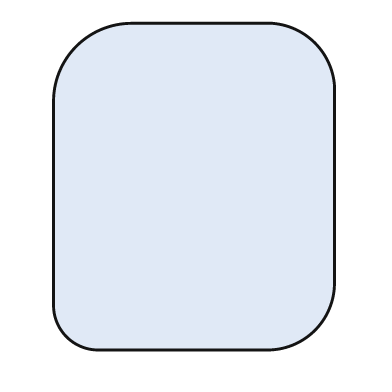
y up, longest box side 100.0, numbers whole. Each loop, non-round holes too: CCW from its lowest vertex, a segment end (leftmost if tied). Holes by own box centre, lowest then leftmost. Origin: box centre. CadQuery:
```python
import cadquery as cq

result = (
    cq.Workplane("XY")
    .moveTo(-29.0, -50.0)
    .lineTo(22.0, -50.0)
    .threePointArc((37.0, -44.0), (43.0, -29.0))
    .lineTo(43.0, 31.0)
    .threePointArc((37.0, 44.0), (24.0, 50.0))
    .lineTo(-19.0, 50.0)
    .threePointArc((-36.0, 43.0), (-43.0, 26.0))
    .lineTo(-43.0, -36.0)
    .threePointArc((-39.0, -46.0), (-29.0, -50.0))
    .close()
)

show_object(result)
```